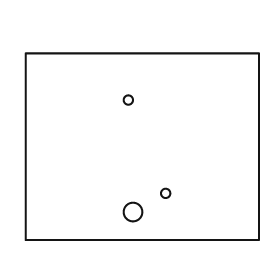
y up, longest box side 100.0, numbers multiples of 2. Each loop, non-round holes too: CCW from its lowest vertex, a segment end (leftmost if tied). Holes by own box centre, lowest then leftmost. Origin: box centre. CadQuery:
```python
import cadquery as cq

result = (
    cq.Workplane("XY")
    .moveTo(-50.0, -40.0)
    .lineTo(50.0, -40.0)
    .lineTo(50.0, 40.0)
    .lineTo(-50.0, 40.0)
    .close()
    .moveTo(-4.0, -28.0)
    .circle(4.0)
    .moveTo(10.0, -20.0)
    .circle(2.0)
    .moveTo(-6.0, 20.0)
    .circle(2.0)
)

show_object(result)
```